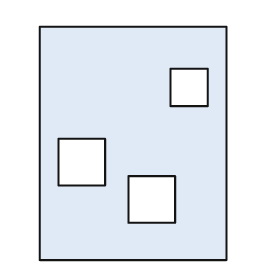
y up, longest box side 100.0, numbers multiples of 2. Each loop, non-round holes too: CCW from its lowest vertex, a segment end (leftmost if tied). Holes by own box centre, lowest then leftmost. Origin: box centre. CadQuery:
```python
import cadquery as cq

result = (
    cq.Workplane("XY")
    .moveTo(-40.0, -50.0)
    .lineTo(40.0, -50.0)
    .lineTo(40.0, 50.0)
    .lineTo(-40.0, 50.0)
    .close()
    .moveTo(-2.0, -34.0)
    .lineTo(18.0, -34.0)
    .lineTo(18.0, -14.0)
    .lineTo(-2.0, -14.0)
    .close()
    .moveTo(-32.0, -18.0)
    .lineTo(-12.0, -18.0)
    .lineTo(-12.0, 2.0)
    .lineTo(-32.0, 2.0)
    .close()
    .moveTo(16.0, 16.0)
    .lineTo(32.0, 16.0)
    .lineTo(32.0, 32.0)
    .lineTo(16.0, 32.0)
    .close()
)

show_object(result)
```